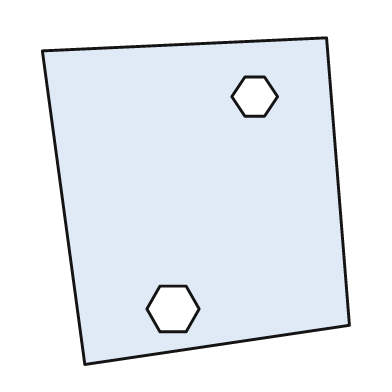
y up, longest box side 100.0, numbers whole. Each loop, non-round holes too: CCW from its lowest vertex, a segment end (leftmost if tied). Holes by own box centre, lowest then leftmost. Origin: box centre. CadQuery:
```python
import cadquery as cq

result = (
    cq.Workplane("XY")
    .moveTo(-34.0, -50.0)
    .lineTo(47.0, -38.0)
    .lineTo(40.0, 50.0)
    .lineTo(-47.0, 46.0)
    .close()
    .moveTo(-11.0, -40.0)
    .lineTo(-3.0, -40.0)
    .lineTo(1.0, -33.0)
    .lineTo(-3.0, -26.0)
    .lineTo(-11.0, -26.0)
    .lineTo(-15.0, -33.0)
    .close()
    .moveTo(15.0, 26.0)
    .lineTo(21.0, 26.0)
    .lineTo(25.0, 32.0)
    .lineTo(21.0, 38.0)
    .lineTo(15.0, 38.0)
    .lineTo(11.0, 32.0)
    .close()
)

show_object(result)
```